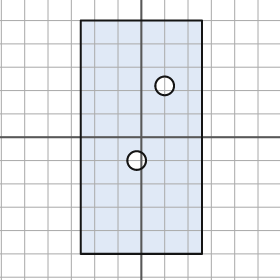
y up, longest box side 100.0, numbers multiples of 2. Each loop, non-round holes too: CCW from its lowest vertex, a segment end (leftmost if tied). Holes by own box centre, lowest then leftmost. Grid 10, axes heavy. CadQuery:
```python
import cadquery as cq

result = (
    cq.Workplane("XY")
    .moveTo(-26.0, -50.0)
    .lineTo(26.0, -50.0)
    .lineTo(26.0, 50.0)
    .lineTo(-26.0, 50.0)
    .close()
    .moveTo(-2.0, -10.0)
    .circle(4.0)
    .moveTo(10.0, 22.0)
    .circle(4.0)
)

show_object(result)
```